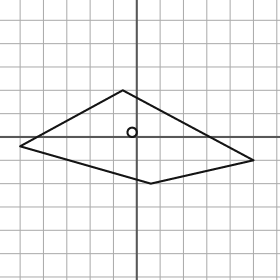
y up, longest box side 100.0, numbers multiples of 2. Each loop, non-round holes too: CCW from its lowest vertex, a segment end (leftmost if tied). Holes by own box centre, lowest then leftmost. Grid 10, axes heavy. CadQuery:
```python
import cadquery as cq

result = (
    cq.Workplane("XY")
    .moveTo(6.0, -20.0)
    .lineTo(50.0, -10.0)
    .lineTo(-6.0, 20.0)
    .lineTo(-50.0, -4.0)
    .close()
    .moveTo(-2.0, 2.0)
    .circle(2.0)
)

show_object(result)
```